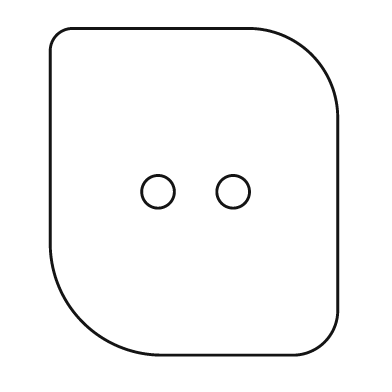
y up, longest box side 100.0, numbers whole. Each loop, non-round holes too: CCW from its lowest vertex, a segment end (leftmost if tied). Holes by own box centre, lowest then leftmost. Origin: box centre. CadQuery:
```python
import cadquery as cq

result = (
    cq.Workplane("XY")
    .moveTo(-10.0, -50.0)
    .lineTo(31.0, -50.0)
    .threePointArc((40.0, -46.0), (44.0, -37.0))
    .lineTo(44.0, 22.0)
    .threePointArc((36.0, 42.0), (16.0, 50.0))
    .lineTo(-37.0, 50.0)
    .threePointArc((-42.0, 48.0), (-44.0, 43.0))
    .lineTo(-44.0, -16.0)
    .threePointArc((-34.0, -40.0), (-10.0, -50.0))
    .close()
    .moveTo(-11.0, 0.0)
    .circle(5.0)
    .moveTo(12.0, 0.0)
    .circle(5.0)
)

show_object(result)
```